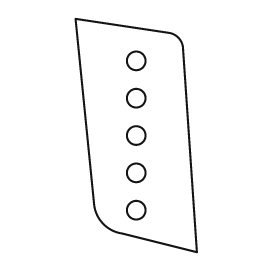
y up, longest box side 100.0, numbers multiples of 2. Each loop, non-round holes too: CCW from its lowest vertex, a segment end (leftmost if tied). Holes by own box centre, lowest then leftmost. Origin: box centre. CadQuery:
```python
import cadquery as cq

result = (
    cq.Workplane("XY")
    .moveTo(26.0, -50.0)
    .lineTo(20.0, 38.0)
    .threePointArc((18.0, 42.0), (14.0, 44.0))
    .lineTo(-26.0, 50.0)
    .lineTo(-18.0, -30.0)
    .threePointArc((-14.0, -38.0), (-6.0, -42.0))
    .close()
    .moveTo(0.0, -32.0)
    .circle(4.0)
    .moveTo(0.0, -16.0)
    .circle(4.0)
    .moveTo(0.0, 0.0)
    .circle(4.0)
    .moveTo(0.0, 16.0)
    .circle(4.0)
    .moveTo(0.0, 32.0)
    .circle(4.0)
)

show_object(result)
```